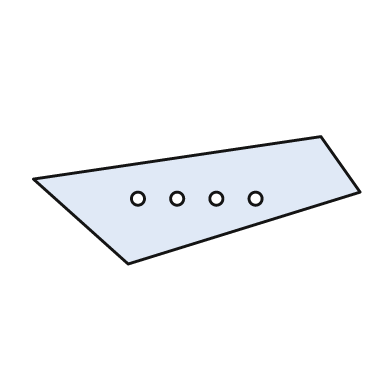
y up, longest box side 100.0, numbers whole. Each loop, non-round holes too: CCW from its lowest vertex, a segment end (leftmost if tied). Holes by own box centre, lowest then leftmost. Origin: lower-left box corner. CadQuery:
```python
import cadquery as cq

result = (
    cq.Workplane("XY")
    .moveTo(29.0, 0.0)
    .lineTo(100.0, 22.0)
    .lineTo(88.0, 39.0)
    .lineTo(0.0, 26.0)
    .close()
    .moveTo(32.0, 20.0)
    .circle(2.0)
    .moveTo(44.0, 20.0)
    .circle(2.0)
    .moveTo(56.0, 20.0)
    .circle(2.0)
    .moveTo(68.0, 20.0)
    .circle(2.0)
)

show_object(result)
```